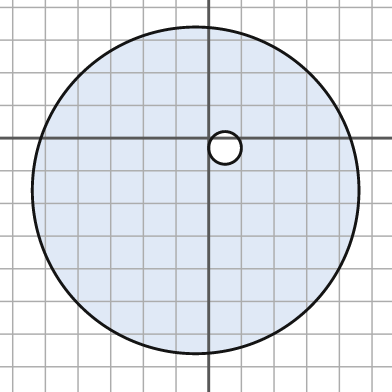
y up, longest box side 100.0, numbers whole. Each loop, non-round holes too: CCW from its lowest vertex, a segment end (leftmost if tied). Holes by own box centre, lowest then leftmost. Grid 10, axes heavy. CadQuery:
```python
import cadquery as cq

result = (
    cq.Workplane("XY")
    .moveTo(-4.0, -16.0)
    .circle(50.0)
    .moveTo(5.0, -3.0)
    .circle(5.0)
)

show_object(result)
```